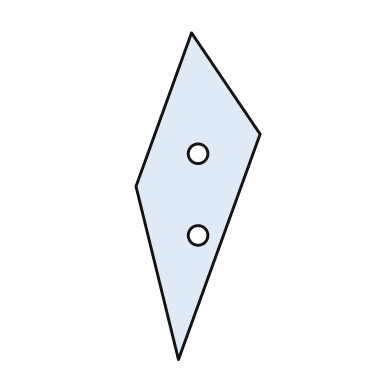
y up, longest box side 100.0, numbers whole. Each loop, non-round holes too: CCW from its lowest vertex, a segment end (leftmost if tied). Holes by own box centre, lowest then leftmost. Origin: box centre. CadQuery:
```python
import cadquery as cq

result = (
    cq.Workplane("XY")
    .moveTo(-6.0, -50.0)
    .lineTo(19.0, 19.0)
    .lineTo(-2.0, 50.0)
    .lineTo(-19.0, 3.0)
    .close()
    .moveTo(0.0, -12.0)
    .circle(3.0)
    .moveTo(0.0, 13.0)
    .circle(3.0)
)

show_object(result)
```